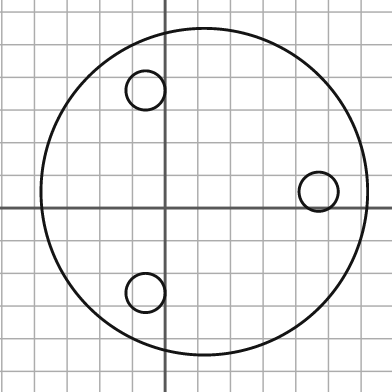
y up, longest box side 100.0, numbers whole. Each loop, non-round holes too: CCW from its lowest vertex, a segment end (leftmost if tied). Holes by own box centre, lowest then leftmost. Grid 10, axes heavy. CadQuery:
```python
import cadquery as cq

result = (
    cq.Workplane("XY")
    .moveTo(12.0, 5.0)
    .circle(50.0)
    .moveTo(-6.0, -26.0)
    .circle(6.0)
    .moveTo(47.0, 5.0)
    .circle(6.0)
    .moveTo(-6.0, 36.0)
    .circle(6.0)
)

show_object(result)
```